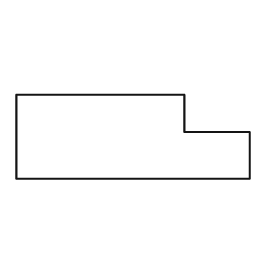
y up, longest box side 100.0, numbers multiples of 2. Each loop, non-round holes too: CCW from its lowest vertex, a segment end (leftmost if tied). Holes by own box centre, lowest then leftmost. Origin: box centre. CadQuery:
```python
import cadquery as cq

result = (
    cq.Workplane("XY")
    .moveTo(-50.0, -18.0)
    .lineTo(50.0, -18.0)
    .lineTo(50.0, 2.0)
    .lineTo(22.0, 2.0)
    .lineTo(22.0, 18.0)
    .lineTo(-50.0, 18.0)
    .close()
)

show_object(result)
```